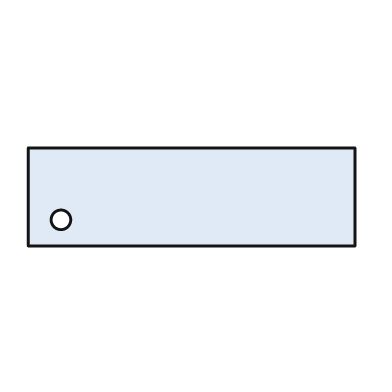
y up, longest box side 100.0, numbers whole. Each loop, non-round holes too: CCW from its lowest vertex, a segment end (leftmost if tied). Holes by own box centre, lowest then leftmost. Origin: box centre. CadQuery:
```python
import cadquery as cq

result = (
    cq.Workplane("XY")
    .moveTo(-50.0, -15.0)
    .lineTo(50.0, -15.0)
    .lineTo(50.0, 15.0)
    .lineTo(-50.0, 15.0)
    .close()
    .moveTo(-40.0, -7.0)
    .circle(3.0)
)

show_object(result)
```